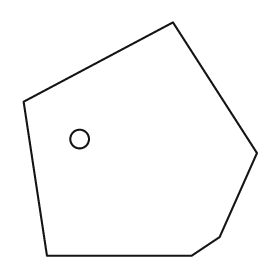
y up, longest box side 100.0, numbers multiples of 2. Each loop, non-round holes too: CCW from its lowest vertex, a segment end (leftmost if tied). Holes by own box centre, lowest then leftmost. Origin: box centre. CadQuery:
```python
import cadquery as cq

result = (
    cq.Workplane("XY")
    .moveTo(-40.0, -50.0)
    .lineTo(22.0, -50.0)
    .lineTo(34.0, -42.0)
    .lineTo(50.0, -6.0)
    .lineTo(14.0, 50.0)
    .lineTo(-50.0, 16.0)
    .close()
    .moveTo(-26.0, 0.0)
    .circle(4.0)
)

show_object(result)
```